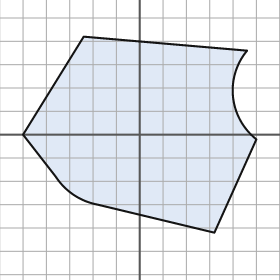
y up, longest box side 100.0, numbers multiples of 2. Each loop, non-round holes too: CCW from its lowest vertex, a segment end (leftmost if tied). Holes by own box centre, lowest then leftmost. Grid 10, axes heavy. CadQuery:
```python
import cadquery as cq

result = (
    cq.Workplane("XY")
    .moveTo(32.0, -42.0)
    .lineTo(50.0, -2.0)
    .threePointArc((40.0, 16.0), (46.0, 36.0))
    .lineTo(-24.0, 42.0)
    .lineTo(-50.0, 0.0)
    .lineTo(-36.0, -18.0)
    .threePointArc((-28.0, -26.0), (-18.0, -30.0))
    .close()
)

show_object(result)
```